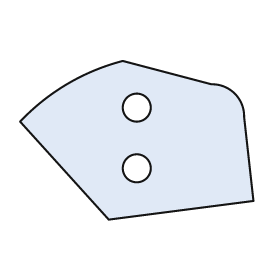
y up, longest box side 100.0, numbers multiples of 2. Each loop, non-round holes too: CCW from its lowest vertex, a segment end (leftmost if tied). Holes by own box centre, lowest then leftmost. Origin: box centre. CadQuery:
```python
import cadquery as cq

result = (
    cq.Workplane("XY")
    .moveTo(-12.0, -34.0)
    .lineTo(50.0, -26.0)
    .lineTo(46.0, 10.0)
    .threePointArc((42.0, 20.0), (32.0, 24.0))
    .lineTo(-6.0, 34.0)
    .threePointArc((-30.0, 24.0), (-50.0, 8.0))
    .close()
    .moveTo(0.0, -12.0)
    .circle(6.0)
    .moveTo(0.0, 14.0)
    .circle(6.0)
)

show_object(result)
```